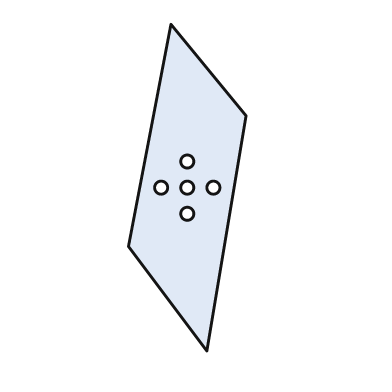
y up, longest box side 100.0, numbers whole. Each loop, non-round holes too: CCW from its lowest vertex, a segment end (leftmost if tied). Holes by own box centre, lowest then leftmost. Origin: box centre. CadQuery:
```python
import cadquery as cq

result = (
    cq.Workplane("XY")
    .moveTo(6.0, -50.0)
    .lineTo(18.0, 22.0)
    .lineTo(-5.0, 50.0)
    .lineTo(-18.0, -18.0)
    .close()
    .moveTo(0.0, -8.0)
    .circle(2.0)
    .moveTo(-8.0, 0.0)
    .circle(2.0)
    .moveTo(0.0, 0.0)
    .circle(2.0)
    .moveTo(8.0, 0.0)
    .circle(2.0)
    .moveTo(0.0, 8.0)
    .circle(2.0)
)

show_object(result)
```